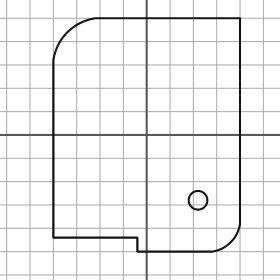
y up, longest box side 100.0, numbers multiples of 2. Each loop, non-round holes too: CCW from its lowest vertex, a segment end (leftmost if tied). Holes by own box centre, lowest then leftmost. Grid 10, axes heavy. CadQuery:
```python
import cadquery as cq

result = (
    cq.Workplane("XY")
    .moveTo(-4.0, -50.0)
    .lineTo(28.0, -50.0)
    .threePointArc((36.0, -46.0), (40.0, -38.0))
    .lineTo(40.0, 50.0)
    .lineTo(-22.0, 50.0)
    .threePointArc((-34.0, 44.0), (-40.0, 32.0))
    .lineTo(-40.0, -44.0)
    .lineTo(-4.0, -44.0)
    .close()
    .moveTo(22.0, -28.0)
    .circle(4.0)
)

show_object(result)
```